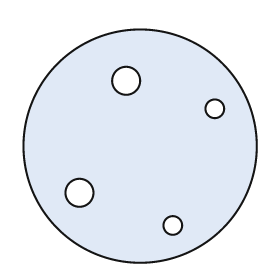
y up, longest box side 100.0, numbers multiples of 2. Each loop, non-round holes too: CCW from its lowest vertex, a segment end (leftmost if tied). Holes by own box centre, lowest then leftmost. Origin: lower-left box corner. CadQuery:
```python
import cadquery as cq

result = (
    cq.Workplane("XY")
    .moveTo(50.0, 50.0)
    .circle(50.0)
    .moveTo(64.0, 16.0)
    .circle(4.0)
    .moveTo(24.0, 30.0)
    .circle(6.0)
    .moveTo(82.0, 66.0)
    .circle(4.0)
    .moveTo(44.0, 78.0)
    .circle(6.0)
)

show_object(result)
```